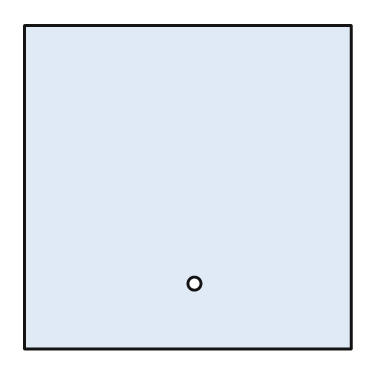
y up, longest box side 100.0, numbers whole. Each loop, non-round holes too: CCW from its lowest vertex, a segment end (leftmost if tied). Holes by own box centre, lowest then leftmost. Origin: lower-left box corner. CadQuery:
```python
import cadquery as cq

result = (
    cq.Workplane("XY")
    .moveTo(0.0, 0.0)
    .lineTo(100.0, 0.0)
    .lineTo(100.0, 99.0)
    .lineTo(0.0, 99.0)
    .close()
    .moveTo(52.0, 20.0)
    .circle(2.0)
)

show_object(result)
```